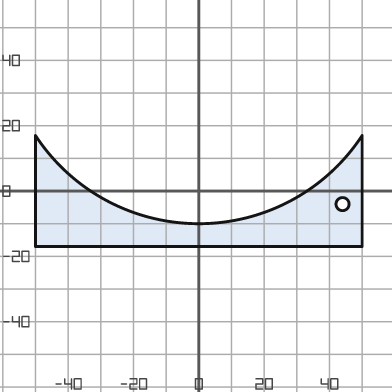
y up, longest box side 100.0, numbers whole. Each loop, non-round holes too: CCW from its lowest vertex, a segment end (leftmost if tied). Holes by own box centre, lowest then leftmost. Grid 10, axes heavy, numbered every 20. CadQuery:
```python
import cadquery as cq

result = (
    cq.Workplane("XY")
    .moveTo(-50.0, -17.0)
    .lineTo(50.0, -17.0)
    .lineTo(50.0, 17.0)
    .threePointArc((0.0, -10.0), (-50.0, 17.0))
    .close()
    .moveTo(44.0, -4.0)
    .circle(2.0)
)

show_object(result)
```